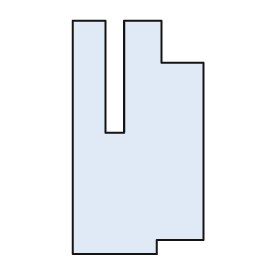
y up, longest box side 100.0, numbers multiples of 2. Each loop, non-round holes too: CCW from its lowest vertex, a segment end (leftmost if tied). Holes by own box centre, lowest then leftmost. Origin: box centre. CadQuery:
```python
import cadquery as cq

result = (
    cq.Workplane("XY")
    .moveTo(-28.0, -50.0)
    .lineTo(8.0, -50.0)
    .lineTo(8.0, -44.0)
    .lineTo(28.0, -44.0)
    .lineTo(28.0, 32.0)
    .lineTo(10.0, 32.0)
    .lineTo(10.0, 50.0)
    .lineTo(-6.0, 50.0)
    .lineTo(-6.0, 2.0)
    .lineTo(-14.0, 2.0)
    .lineTo(-14.0, 50.0)
    .lineTo(-28.0, 50.0)
    .close()
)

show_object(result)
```